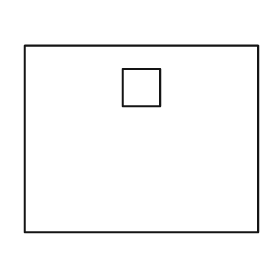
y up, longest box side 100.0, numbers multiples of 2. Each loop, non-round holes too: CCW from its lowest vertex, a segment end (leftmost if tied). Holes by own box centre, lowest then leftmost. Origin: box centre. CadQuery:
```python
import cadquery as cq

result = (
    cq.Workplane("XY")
    .moveTo(-50.0, -40.0)
    .lineTo(50.0, -40.0)
    .lineTo(50.0, 40.0)
    .lineTo(-50.0, 40.0)
    .close()
    .moveTo(-8.0, 14.0)
    .lineTo(8.0, 14.0)
    .lineTo(8.0, 30.0)
    .lineTo(-8.0, 30.0)
    .close()
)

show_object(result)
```